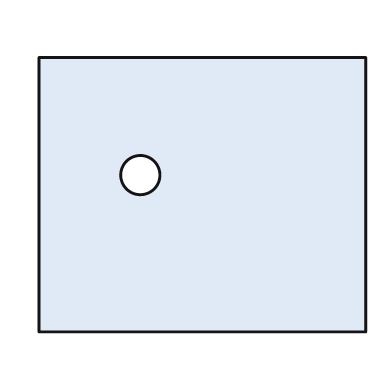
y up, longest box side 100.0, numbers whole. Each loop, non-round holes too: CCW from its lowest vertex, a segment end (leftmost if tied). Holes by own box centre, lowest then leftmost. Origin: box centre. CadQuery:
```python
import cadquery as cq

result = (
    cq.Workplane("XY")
    .moveTo(-50.0, -42.0)
    .lineTo(50.0, -42.0)
    .lineTo(50.0, 42.0)
    .lineTo(-50.0, 42.0)
    .close()
    .moveTo(-19.0, 6.0)
    .circle(6.0)
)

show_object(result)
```